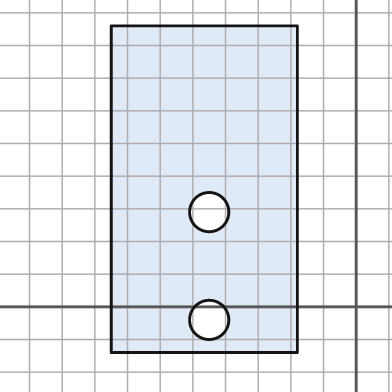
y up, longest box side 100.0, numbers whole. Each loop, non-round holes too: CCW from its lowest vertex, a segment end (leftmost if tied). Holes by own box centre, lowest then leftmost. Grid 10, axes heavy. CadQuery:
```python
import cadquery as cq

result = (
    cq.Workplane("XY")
    .moveTo(-75.0, -14.0)
    .lineTo(-18.0, -14.0)
    .lineTo(-18.0, 86.0)
    .lineTo(-75.0, 86.0)
    .close()
    .moveTo(-45.0, -4.0)
    .circle(6.0)
    .moveTo(-45.0, 29.0)
    .circle(6.0)
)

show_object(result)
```